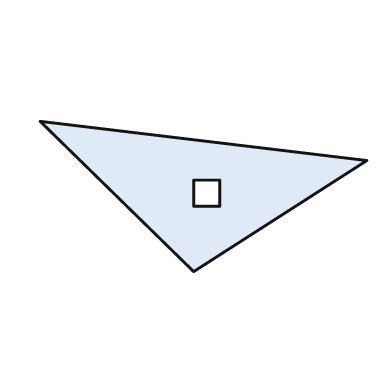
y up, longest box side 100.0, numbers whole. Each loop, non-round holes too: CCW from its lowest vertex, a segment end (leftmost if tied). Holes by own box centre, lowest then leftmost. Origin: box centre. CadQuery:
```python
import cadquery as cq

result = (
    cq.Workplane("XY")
    .moveTo(-3.0, -23.0)
    .lineTo(50.0, 11.0)
    .lineTo(-50.0, 23.0)
    .close()
    .moveTo(-3.0, -3.0)
    .lineTo(5.0, -3.0)
    .lineTo(5.0, 5.0)
    .lineTo(-3.0, 5.0)
    .close()
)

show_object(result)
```